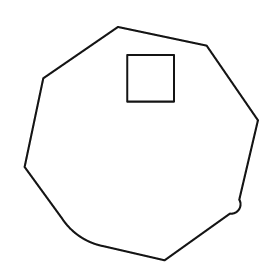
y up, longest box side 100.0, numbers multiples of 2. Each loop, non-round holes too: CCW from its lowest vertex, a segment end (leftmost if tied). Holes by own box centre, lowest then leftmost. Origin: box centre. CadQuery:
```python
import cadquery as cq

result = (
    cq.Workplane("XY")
    .moveTo(10.0, -50.0)
    .lineTo(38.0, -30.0)
    .threePointArc((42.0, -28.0), (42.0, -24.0))
    .lineTo(50.0, 10.0)
    .lineTo(28.0, 42.0)
    .lineTo(-10.0, 50.0)
    .lineTo(-42.0, 28.0)
    .lineTo(-50.0, -10.0)
    .lineTo(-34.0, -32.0)
    .threePointArc((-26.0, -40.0), (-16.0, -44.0))
    .close()
    .moveTo(-6.0, 18.0)
    .lineTo(14.0, 18.0)
    .lineTo(14.0, 38.0)
    .lineTo(-6.0, 38.0)
    .close()
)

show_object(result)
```